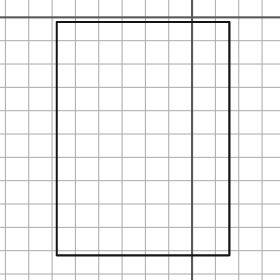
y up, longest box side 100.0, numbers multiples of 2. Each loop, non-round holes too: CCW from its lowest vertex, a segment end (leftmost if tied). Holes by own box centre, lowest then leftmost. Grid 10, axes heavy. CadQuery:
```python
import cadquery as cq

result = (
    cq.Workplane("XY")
    .moveTo(-58.0, -102.0)
    .lineTo(16.0, -102.0)
    .lineTo(16.0, -2.0)
    .lineTo(-58.0, -2.0)
    .close()
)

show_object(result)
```